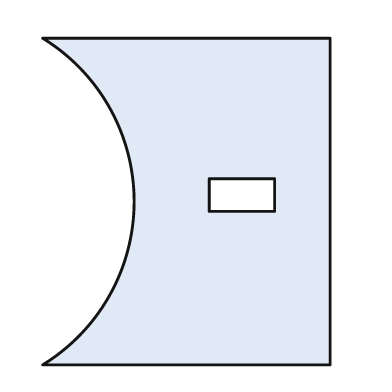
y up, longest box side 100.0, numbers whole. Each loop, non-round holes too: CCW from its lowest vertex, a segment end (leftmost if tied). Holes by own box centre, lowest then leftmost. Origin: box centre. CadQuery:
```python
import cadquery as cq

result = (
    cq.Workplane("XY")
    .moveTo(-44.0, -50.0)
    .lineTo(44.0, -50.0)
    .lineTo(44.0, 50.0)
    .lineTo(-44.0, 50.0)
    .threePointArc((-16.0, 0.0), (-44.0, -50.0))
    .close()
    .moveTo(7.0, -3.0)
    .lineTo(27.0, -3.0)
    .lineTo(27.0, 7.0)
    .lineTo(7.0, 7.0)
    .close()
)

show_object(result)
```